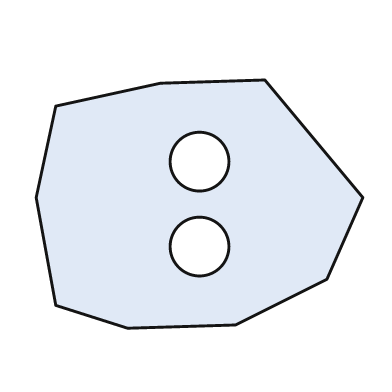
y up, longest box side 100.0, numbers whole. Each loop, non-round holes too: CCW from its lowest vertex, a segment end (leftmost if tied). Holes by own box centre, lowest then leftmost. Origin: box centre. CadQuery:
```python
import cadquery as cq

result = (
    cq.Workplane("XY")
    .moveTo(-22.0, -38.0)
    .lineTo(11.0, -37.0)
    .lineTo(39.0, -23.0)
    .lineTo(50.0, 2.0)
    .lineTo(20.0, 38.0)
    .lineTo(-12.0, 37.0)
    .lineTo(-44.0, 30.0)
    .lineTo(-50.0, 2.0)
    .lineTo(-44.0, -31.0)
    .close()
    .moveTo(0.0, -13.0)
    .circle(9.0)
    .moveTo(0.0, 13.0)
    .circle(9.0)
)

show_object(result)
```